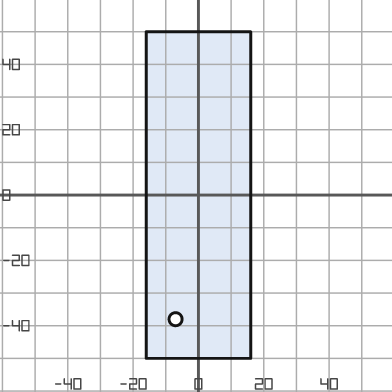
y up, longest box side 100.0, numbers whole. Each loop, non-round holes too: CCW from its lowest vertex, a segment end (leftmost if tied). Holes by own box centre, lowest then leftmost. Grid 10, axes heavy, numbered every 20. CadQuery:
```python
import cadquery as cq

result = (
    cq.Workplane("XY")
    .moveTo(-16.0, -50.0)
    .lineTo(16.0, -50.0)
    .lineTo(16.0, 50.0)
    .lineTo(-16.0, 50.0)
    .close()
    .moveTo(-7.0, -38.0)
    .circle(2.0)
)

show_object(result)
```